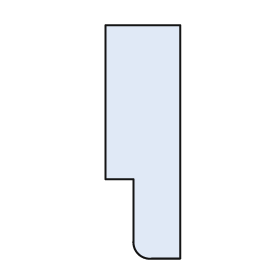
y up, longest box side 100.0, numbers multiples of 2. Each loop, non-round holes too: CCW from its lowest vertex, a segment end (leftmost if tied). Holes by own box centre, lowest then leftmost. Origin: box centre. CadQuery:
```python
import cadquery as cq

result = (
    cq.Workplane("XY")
    .moveTo(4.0, -50.0)
    .lineTo(16.0, -50.0)
    .lineTo(16.0, 50.0)
    .lineTo(-16.0, 50.0)
    .lineTo(-16.0, -16.0)
    .lineTo(-4.0, -16.0)
    .lineTo(-4.0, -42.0)
    .threePointArc((-2.0, -48.0), (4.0, -50.0))
    .close()
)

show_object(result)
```